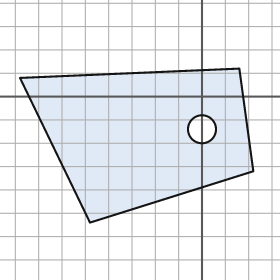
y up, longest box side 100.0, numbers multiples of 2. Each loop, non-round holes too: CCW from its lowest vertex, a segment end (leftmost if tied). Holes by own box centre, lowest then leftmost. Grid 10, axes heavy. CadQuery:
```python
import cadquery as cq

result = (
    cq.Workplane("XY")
    .moveTo(-48.0, -54.0)
    .lineTo(22.0, -32.0)
    .lineTo(16.0, 12.0)
    .lineTo(-78.0, 8.0)
    .close()
    .moveTo(0.0, -14.0)
    .circle(6.0)
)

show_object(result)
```